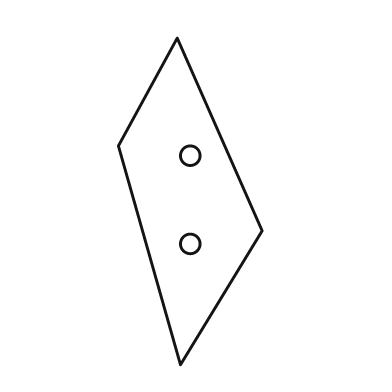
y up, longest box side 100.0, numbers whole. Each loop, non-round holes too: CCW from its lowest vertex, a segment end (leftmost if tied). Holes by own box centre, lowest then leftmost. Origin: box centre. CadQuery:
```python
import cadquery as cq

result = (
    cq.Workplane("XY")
    .moveTo(-3.0, -50.0)
    .lineTo(22.0, -9.0)
    .lineTo(-4.0, 50.0)
    .lineTo(-22.0, 17.0)
    .close()
    .moveTo(0.0, -13.0)
    .circle(3.0)
    .moveTo(0.0, 14.0)
    .circle(3.0)
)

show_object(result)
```